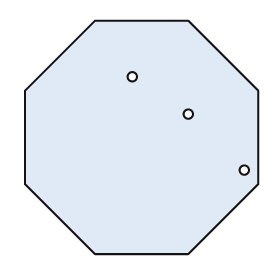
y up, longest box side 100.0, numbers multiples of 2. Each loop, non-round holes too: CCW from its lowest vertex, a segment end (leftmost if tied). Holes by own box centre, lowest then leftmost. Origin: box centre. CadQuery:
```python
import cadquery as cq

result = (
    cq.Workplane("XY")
    .moveTo(-20.0, -50.0)
    .lineTo(20.0, -50.0)
    .lineTo(50.0, -20.0)
    .lineTo(50.0, 20.0)
    .lineTo(20.0, 50.0)
    .lineTo(-20.0, 50.0)
    .lineTo(-50.0, 20.0)
    .lineTo(-50.0, -20.0)
    .close()
    .moveTo(44.0, -14.0)
    .circle(2.0)
    .moveTo(20.0, 10.0)
    .circle(2.0)
    .moveTo(-4.0, 26.0)
    .circle(2.0)
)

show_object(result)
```